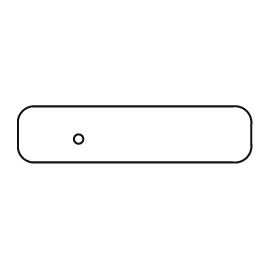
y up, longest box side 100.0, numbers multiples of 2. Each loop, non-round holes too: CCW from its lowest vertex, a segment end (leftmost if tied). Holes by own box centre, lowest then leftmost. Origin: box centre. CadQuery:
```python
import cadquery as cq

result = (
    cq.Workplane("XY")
    .moveTo(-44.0, -12.0)
    .lineTo(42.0, -12.0)
    .threePointArc((48.0, -10.0), (50.0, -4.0))
    .lineTo(50.0, 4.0)
    .threePointArc((48.0, 10.0), (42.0, 12.0))
    .lineTo(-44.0, 12.0)
    .threePointArc((-48.0, 10.0), (-50.0, 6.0))
    .lineTo(-50.0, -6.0)
    .threePointArc((-48.0, -10.0), (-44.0, -12.0))
    .close()
    .moveTo(-24.0, -2.0)
    .circle(2.0)
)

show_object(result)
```